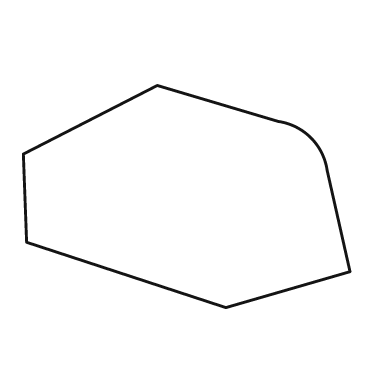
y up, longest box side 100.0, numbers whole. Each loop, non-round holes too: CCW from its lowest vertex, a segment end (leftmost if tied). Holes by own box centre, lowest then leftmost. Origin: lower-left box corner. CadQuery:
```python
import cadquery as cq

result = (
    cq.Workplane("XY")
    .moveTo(62.0, 0.0)
    .lineTo(100.0, 11.0)
    .lineTo(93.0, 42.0)
    .threePointArc((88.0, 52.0), (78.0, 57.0))
    .lineTo(41.0, 68.0)
    .lineTo(0.0, 47.0)
    .lineTo(1.0, 20.0)
    .close()
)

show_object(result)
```